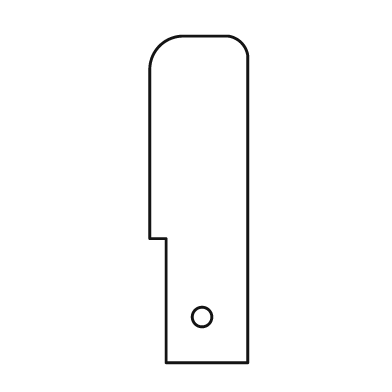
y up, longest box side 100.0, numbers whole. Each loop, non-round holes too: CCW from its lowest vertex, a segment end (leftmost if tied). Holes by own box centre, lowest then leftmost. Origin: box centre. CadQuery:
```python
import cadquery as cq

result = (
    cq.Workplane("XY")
    .moveTo(-10.0, -50.0)
    .lineTo(15.0, -50.0)
    .lineTo(15.0, 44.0)
    .threePointArc((13.0, 48.0), (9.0, 50.0))
    .lineTo(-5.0, 50.0)
    .threePointArc((-12.0, 47.0), (-15.0, 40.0))
    .lineTo(-15.0, -12.0)
    .lineTo(-10.0, -12.0)
    .close()
    .moveTo(1.0, -36.0)
    .circle(3.0)
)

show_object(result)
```